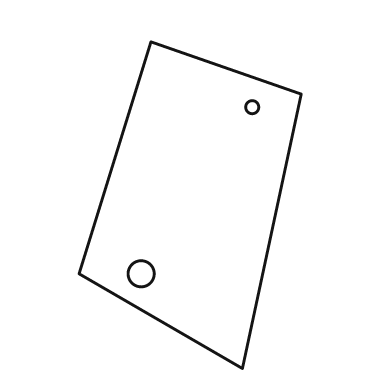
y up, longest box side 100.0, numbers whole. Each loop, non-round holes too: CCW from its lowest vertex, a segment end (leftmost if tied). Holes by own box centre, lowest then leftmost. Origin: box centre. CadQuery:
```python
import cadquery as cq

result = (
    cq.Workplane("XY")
    .moveTo(16.0, -50.0)
    .lineTo(34.0, 34.0)
    .lineTo(-12.0, 50.0)
    .lineTo(-34.0, -21.0)
    .close()
    .moveTo(-15.0, -21.0)
    .circle(4.0)
    .moveTo(19.0, 30.0)
    .circle(2.0)
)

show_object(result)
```